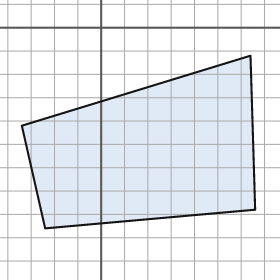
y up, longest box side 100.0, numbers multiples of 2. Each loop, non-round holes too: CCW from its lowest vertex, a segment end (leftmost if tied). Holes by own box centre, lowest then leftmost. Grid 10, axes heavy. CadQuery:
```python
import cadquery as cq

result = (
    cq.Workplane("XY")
    .moveTo(-24.0, -86.0)
    .lineTo(66.0, -78.0)
    .lineTo(64.0, -12.0)
    .lineTo(-34.0, -42.0)
    .close()
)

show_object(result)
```